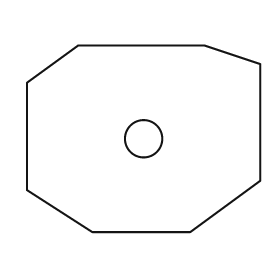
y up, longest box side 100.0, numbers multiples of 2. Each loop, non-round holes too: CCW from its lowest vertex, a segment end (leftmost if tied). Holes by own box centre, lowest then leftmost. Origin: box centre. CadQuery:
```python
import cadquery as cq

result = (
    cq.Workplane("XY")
    .moveTo(-22.0, -40.0)
    .lineTo(20.0, -40.0)
    .lineTo(50.0, -18.0)
    .lineTo(50.0, 32.0)
    .lineTo(26.0, 40.0)
    .lineTo(-28.0, 40.0)
    .lineTo(-50.0, 24.0)
    .lineTo(-50.0, -22.0)
    .close()
    .moveTo(0.0, 0.0)
    .circle(8.0)
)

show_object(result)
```